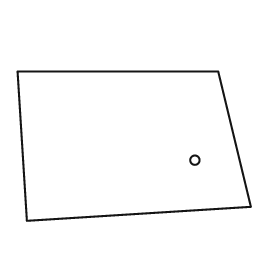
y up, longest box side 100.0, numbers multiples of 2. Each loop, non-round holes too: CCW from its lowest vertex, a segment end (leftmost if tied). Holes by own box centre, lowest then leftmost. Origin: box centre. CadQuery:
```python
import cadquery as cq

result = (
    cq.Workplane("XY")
    .moveTo(-46.0, -32.0)
    .lineTo(50.0, -26.0)
    .lineTo(36.0, 32.0)
    .lineTo(-50.0, 32.0)
    .close()
    .moveTo(26.0, -6.0)
    .circle(2.0)
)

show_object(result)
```